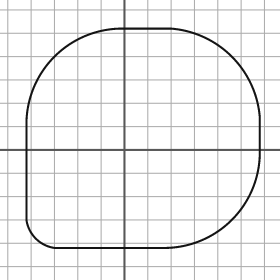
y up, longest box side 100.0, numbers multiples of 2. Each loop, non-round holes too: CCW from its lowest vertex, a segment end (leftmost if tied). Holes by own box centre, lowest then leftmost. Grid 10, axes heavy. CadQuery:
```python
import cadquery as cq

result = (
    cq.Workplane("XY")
    .moveTo(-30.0, -42.0)
    .lineTo(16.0, -42.0)
    .threePointArc((46.0, -30.0), (58.0, 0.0))
    .lineTo(58.0, 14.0)
    .threePointArc((46.0, 40.0), (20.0, 52.0))
    .lineTo(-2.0, 52.0)
    .threePointArc((-30.0, 40.0), (-42.0, 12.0))
    .lineTo(-42.0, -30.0)
    .threePointArc((-38.0, -38.0), (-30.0, -42.0))
    .close()
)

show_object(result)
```